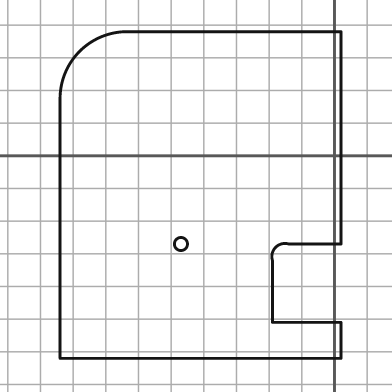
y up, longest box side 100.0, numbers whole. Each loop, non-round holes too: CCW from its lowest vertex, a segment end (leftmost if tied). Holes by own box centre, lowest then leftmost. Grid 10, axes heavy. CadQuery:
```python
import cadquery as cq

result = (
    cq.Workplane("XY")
    .moveTo(-84.0, -62.0)
    .lineTo(2.0, -62.0)
    .lineTo(2.0, -51.0)
    .lineTo(-19.0, -51.0)
    .lineTo(-19.0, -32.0)
    .threePointArc((-18.0, -28.0), (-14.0, -27.0))
    .lineTo(2.0, -27.0)
    .lineTo(2.0, 38.0)
    .lineTo(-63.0, 38.0)
    .threePointArc((-78.0, 32.0), (-84.0, 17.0))
    .close()
    .moveTo(-47.0, -27.0)
    .circle(2.0)
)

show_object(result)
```